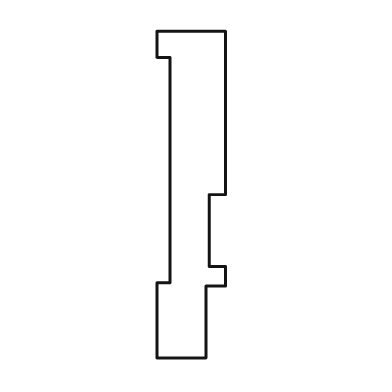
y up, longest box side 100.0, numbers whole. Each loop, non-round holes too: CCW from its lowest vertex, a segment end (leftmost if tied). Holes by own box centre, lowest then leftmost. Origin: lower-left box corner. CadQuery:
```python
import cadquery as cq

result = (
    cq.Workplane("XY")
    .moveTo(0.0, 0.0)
    .lineTo(15.0, 0.0)
    .lineTo(15.0, 22.0)
    .lineTo(21.0, 22.0)
    .lineTo(21.0, 28.0)
    .lineTo(16.0, 28.0)
    .lineTo(16.0, 50.0)
    .lineTo(21.0, 50.0)
    .lineTo(21.0, 100.0)
    .lineTo(0.0, 100.0)
    .lineTo(0.0, 92.0)
    .lineTo(4.0, 92.0)
    .lineTo(4.0, 23.0)
    .lineTo(0.0, 23.0)
    .close()
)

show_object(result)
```